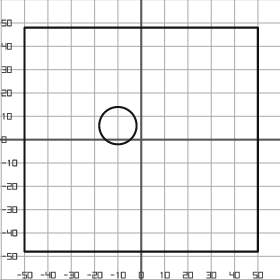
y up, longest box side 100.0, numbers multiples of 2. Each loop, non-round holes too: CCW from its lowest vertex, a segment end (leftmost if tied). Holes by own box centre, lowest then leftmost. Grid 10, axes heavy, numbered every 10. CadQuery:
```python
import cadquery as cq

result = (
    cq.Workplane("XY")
    .moveTo(-50.0, -48.0)
    .lineTo(50.0, -48.0)
    .lineTo(50.0, 48.0)
    .lineTo(-50.0, 48.0)
    .close()
    .moveTo(-10.0, 6.0)
    .circle(8.0)
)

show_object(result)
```